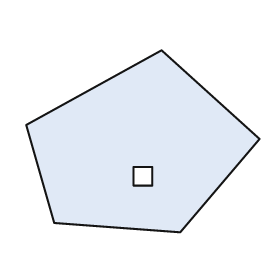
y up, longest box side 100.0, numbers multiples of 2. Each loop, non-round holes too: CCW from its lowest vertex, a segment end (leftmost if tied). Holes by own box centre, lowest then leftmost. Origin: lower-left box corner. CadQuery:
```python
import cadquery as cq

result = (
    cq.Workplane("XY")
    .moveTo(66.0, 0.0)
    .lineTo(100.0, 40.0)
    .lineTo(58.0, 78.0)
    .lineTo(0.0, 46.0)
    .lineTo(12.0, 4.0)
    .close()
    .moveTo(46.0, 20.0)
    .lineTo(54.0, 20.0)
    .lineTo(54.0, 28.0)
    .lineTo(46.0, 28.0)
    .close()
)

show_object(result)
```